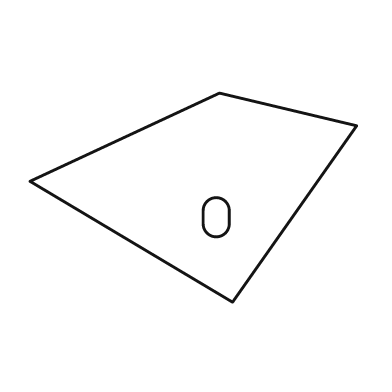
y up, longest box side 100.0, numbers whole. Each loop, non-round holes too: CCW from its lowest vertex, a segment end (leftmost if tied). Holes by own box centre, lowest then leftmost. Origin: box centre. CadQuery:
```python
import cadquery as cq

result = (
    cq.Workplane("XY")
    .moveTo(12.0, -32.0)
    .lineTo(50.0, 22.0)
    .lineTo(8.0, 32.0)
    .lineTo(-50.0, 5.0)
    .close()
    .moveTo(3.0, -8.0)
    .threePointArc((7.0, -12.0), (11.0, -8.0))
    .lineTo(11.0, -4.0)
    .threePointArc((7.0, 0.0), (3.0, -4.0))
    .close()
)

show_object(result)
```